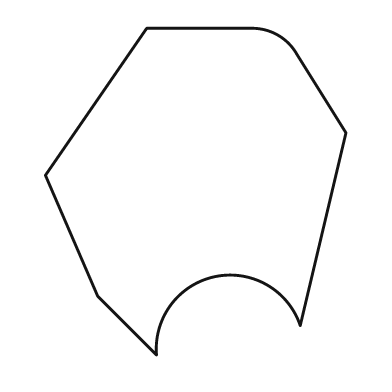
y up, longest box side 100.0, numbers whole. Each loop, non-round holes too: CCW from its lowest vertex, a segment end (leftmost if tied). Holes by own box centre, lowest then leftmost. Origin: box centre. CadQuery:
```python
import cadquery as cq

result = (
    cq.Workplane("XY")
    .moveTo(-12.0, -50.0)
    .threePointArc((6.0, -26.0), (32.0, -41.0))
    .lineTo(46.0, 18.0)
    .lineTo(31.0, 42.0)
    .threePointArc((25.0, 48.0), (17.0, 50.0))
    .lineTo(-15.0, 50.0)
    .lineTo(-46.0, 5.0)
    .lineTo(-30.0, -32.0)
    .close()
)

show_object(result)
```